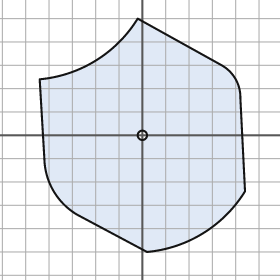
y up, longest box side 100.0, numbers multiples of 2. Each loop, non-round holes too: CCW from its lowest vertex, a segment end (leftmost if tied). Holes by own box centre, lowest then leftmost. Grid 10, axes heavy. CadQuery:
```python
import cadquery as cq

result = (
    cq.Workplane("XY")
    .moveTo(2.0, -50.0)
    .threePointArc((26.0, -42.0), (44.0, -24.0))
    .lineTo(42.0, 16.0)
    .threePointArc((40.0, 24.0), (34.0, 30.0))
    .lineTo(-2.0, 50.0)
    .threePointArc((-20.0, 32.0), (-44.0, 24.0))
    .lineTo(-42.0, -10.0)
    .threePointArc((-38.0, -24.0), (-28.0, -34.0))
    .close()
    .moveTo(0.0, 0.0)
    .circle(2.0)
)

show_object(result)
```